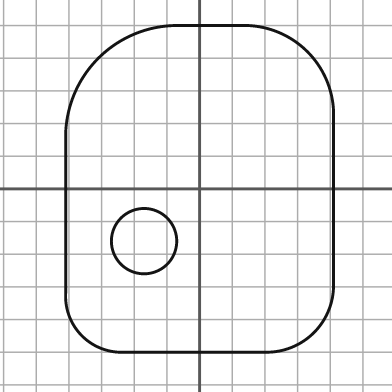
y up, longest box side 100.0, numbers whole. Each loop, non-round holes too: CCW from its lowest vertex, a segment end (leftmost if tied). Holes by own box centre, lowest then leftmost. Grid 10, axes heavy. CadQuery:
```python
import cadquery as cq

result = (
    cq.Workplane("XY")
    .moveTo(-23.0, -50.0)
    .lineTo(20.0, -50.0)
    .threePointArc((35.0, -44.0), (41.0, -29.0))
    .lineTo(41.0, 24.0)
    .threePointArc((33.0, 42.0), (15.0, 50.0))
    .lineTo(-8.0, 50.0)
    .threePointArc((-31.0, 40.0), (-41.0, 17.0))
    .lineTo(-41.0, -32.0)
    .threePointArc((-36.0, -45.0), (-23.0, -50.0))
    .close()
    .moveTo(-17.0, -16.0)
    .circle(10.0)
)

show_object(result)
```